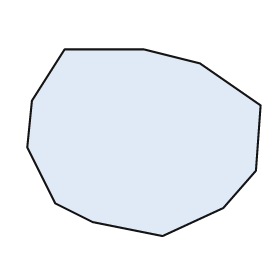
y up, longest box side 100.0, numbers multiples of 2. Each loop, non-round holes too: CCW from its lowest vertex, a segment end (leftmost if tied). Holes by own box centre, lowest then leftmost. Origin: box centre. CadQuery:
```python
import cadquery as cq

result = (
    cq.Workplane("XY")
    .moveTo(8.0, -40.0)
    .lineTo(34.0, -28.0)
    .lineTo(48.0, -12.0)
    .lineTo(50.0, 16.0)
    .lineTo(24.0, 34.0)
    .lineTo(0.0, 40.0)
    .lineTo(-34.0, 40.0)
    .lineTo(-48.0, 18.0)
    .lineTo(-50.0, -2.0)
    .lineTo(-38.0, -26.0)
    .lineTo(-22.0, -34.0)
    .close()
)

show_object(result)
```